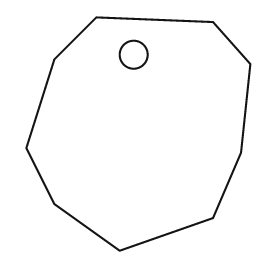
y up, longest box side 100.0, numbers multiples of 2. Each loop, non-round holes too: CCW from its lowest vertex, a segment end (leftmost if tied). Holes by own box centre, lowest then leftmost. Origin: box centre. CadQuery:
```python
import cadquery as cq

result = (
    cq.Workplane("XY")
    .moveTo(-8.0, -50.0)
    .lineTo(32.0, -36.0)
    .lineTo(44.0, -8.0)
    .lineTo(48.0, 30.0)
    .lineTo(32.0, 48.0)
    .lineTo(-18.0, 50.0)
    .lineTo(-36.0, 32.0)
    .lineTo(-48.0, -6.0)
    .lineTo(-36.0, -30.0)
    .close()
    .moveTo(-2.0, 34.0)
    .circle(6.0)
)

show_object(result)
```